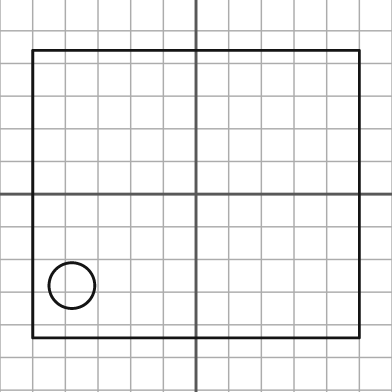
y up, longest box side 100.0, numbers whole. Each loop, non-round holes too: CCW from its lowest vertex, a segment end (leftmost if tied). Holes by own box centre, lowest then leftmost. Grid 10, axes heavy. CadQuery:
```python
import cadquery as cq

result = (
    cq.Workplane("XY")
    .moveTo(-50.0, -44.0)
    .lineTo(50.0, -44.0)
    .lineTo(50.0, 44.0)
    .lineTo(-50.0, 44.0)
    .close()
    .moveTo(-38.0, -28.0)
    .circle(7.0)
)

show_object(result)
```